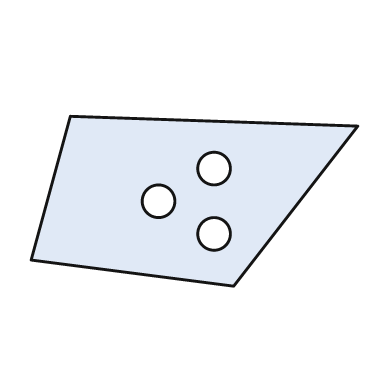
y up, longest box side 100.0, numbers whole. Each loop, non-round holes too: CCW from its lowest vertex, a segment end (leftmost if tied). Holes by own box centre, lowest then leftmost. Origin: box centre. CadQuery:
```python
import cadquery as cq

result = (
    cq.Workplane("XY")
    .moveTo(12.0, -26.0)
    .lineTo(50.0, 23.0)
    .lineTo(-38.0, 26.0)
    .lineTo(-50.0, -18.0)
    .close()
    .moveTo(6.0, -10.0)
    .circle(5.0)
    .moveTo(-11.0, 0.0)
    .circle(5.0)
    .moveTo(6.0, 10.0)
    .circle(5.0)
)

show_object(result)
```